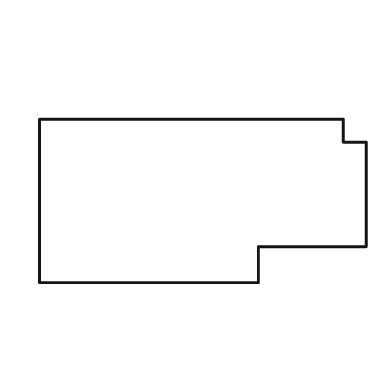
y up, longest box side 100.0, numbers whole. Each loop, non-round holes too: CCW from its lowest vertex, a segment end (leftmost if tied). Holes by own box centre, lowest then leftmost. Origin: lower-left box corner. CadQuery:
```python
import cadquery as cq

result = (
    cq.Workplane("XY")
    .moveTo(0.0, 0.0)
    .lineTo(67.0, 0.0)
    .lineTo(67.0, 11.0)
    .lineTo(100.0, 11.0)
    .lineTo(100.0, 43.0)
    .lineTo(93.0, 43.0)
    .lineTo(93.0, 50.0)
    .lineTo(0.0, 50.0)
    .close()
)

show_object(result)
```